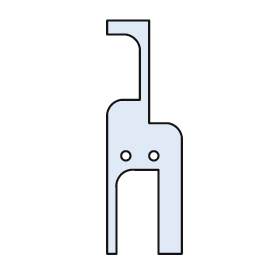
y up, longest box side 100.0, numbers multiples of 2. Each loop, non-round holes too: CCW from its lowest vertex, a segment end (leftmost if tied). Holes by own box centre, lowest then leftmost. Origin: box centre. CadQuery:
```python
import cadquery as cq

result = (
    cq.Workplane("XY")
    .moveTo(-16.0, -50.0)
    .lineTo(-12.0, -50.0)
    .lineTo(-12.0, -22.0)
    .threePointArc((-10.0, -16.0), (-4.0, -14.0))
    .lineTo(6.0, -14.0)
    .lineTo(6.0, -50.0)
    .lineTo(16.0, -50.0)
    .lineTo(16.0, 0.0)
    .threePointArc((14.0, 4.0), (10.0, 6.0))
    .lineTo(2.0, 6.0)
    .lineTo(2.0, 50.0)
    .lineTo(-16.0, 50.0)
    .lineTo(-16.0, 44.0)
    .lineTo(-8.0, 44.0)
    .threePointArc((-4.0, 42.0), (-2.0, 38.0))
    .lineTo(-2.0, 16.0)
    .lineTo(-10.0, 16.0)
    .threePointArc((-14.0, 14.0), (-16.0, 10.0))
    .close()
    .moveTo(-8.0, -8.0)
    .circle(2.0)
    .moveTo(4.0, -8.0)
    .circle(2.0)
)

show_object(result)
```